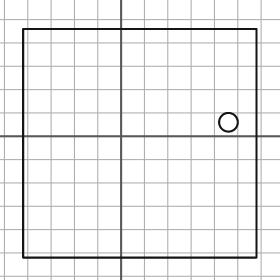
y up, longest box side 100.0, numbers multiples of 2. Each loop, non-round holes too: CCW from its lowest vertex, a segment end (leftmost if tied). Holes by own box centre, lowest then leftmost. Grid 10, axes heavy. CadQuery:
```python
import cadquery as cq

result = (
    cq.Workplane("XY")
    .moveTo(-42.0, -52.0)
    .lineTo(58.0, -52.0)
    .lineTo(58.0, 46.0)
    .lineTo(-42.0, 46.0)
    .close()
    .moveTo(46.0, 6.0)
    .circle(4.0)
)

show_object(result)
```